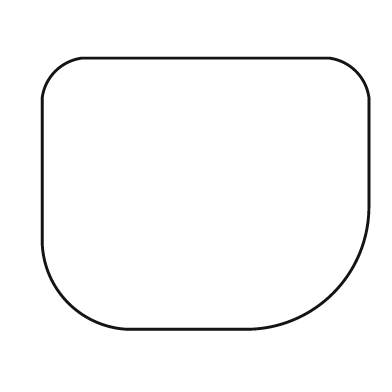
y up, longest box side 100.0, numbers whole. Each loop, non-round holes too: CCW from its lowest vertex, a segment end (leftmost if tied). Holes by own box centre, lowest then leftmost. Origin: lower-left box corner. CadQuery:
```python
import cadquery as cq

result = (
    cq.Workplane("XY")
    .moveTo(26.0, 0.0)
    .lineTo(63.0, 0.0)
    .threePointArc((89.0, 11.0), (100.0, 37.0))
    .lineTo(100.0, 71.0)
    .threePointArc((96.0, 79.0), (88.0, 83.0))
    .lineTo(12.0, 83.0)
    .threePointArc((4.0, 79.0), (0.0, 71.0))
    .lineTo(0.0, 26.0)
    .threePointArc((8.0, 8.0), (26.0, 0.0))
    .close()
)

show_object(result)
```